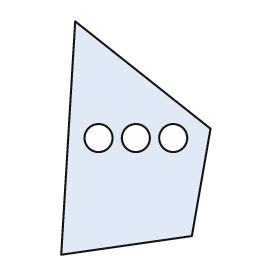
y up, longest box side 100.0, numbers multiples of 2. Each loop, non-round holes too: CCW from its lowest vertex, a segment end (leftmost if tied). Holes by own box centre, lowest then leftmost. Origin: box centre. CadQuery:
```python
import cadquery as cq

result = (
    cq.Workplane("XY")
    .moveTo(-32.0, -50.0)
    .lineTo(24.0, -42.0)
    .lineTo(32.0, 4.0)
    .lineTo(-26.0, 50.0)
    .close()
    .moveTo(-16.0, 0.0)
    .circle(6.0)
    .moveTo(0.0, 0.0)
    .circle(6.0)
    .moveTo(16.0, 0.0)
    .circle(6.0)
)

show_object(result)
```